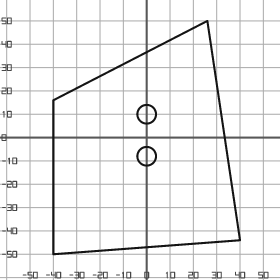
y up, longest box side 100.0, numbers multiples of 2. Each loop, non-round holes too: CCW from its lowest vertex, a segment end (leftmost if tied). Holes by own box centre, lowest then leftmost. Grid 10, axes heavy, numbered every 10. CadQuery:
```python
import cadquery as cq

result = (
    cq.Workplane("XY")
    .moveTo(-40.0, -50.0)
    .lineTo(40.0, -44.0)
    .lineTo(26.0, 50.0)
    .lineTo(-40.0, 16.0)
    .close()
    .moveTo(0.0, -8.0)
    .circle(4.0)
    .moveTo(0.0, 10.0)
    .circle(4.0)
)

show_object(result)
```